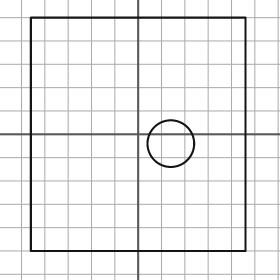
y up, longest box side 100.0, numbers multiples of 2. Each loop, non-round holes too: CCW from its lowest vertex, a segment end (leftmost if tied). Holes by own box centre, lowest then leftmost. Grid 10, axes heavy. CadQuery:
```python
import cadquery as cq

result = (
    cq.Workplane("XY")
    .moveTo(-46.0, -50.0)
    .lineTo(46.0, -50.0)
    .lineTo(46.0, 50.0)
    .lineTo(-46.0, 50.0)
    .close()
    .moveTo(14.0, -4.0)
    .circle(10.0)
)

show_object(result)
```